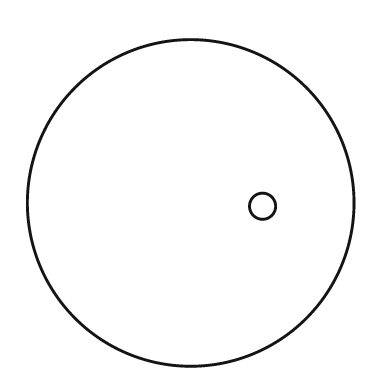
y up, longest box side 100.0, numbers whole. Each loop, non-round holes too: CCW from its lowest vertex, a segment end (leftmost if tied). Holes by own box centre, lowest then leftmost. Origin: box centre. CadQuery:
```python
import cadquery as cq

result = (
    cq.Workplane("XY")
    .moveTo(0.0, 0.0)
    .circle(50.0)
    .moveTo(22.0, -1.0)
    .circle(4.0)
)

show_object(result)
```